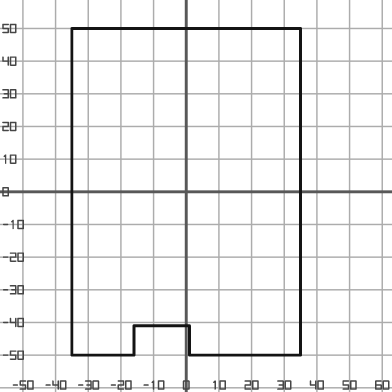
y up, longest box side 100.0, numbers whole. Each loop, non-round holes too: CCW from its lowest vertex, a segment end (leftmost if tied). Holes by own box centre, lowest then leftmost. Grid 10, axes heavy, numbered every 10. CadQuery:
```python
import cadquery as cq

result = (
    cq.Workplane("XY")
    .moveTo(-35.0, -50.0)
    .lineTo(-16.0, -50.0)
    .lineTo(-16.0, -41.0)
    .lineTo(1.0, -41.0)
    .lineTo(1.0, -50.0)
    .lineTo(35.0, -50.0)
    .lineTo(35.0, 50.0)
    .lineTo(-35.0, 50.0)
    .close()
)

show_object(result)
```